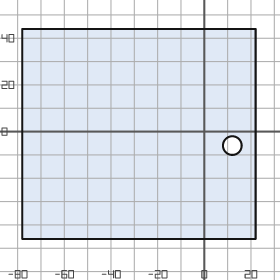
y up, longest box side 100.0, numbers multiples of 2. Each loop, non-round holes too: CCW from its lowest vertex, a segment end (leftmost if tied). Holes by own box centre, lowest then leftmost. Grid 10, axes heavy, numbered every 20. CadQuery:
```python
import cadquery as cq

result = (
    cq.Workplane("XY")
    .moveTo(-78.0, -46.0)
    .lineTo(22.0, -46.0)
    .lineTo(22.0, 44.0)
    .lineTo(-78.0, 44.0)
    .close()
    .moveTo(12.0, -6.0)
    .circle(4.0)
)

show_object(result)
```